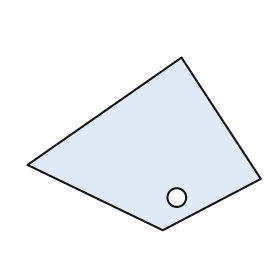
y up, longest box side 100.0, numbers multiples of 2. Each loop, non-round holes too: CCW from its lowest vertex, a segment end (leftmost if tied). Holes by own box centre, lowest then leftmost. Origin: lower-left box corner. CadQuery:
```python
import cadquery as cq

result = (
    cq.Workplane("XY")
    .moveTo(58.0, 0.0)
    .lineTo(100.0, 22.0)
    .lineTo(66.0, 74.0)
    .lineTo(0.0, 28.0)
    .close()
    .moveTo(64.0, 14.0)
    .circle(4.0)
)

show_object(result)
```